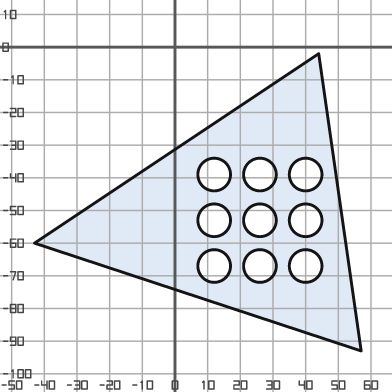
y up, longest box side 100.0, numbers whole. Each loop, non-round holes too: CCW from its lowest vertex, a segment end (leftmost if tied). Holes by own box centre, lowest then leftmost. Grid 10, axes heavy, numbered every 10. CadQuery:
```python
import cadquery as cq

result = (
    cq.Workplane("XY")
    .moveTo(57.0, -93.0)
    .lineTo(44.0, -2.0)
    .lineTo(-43.0, -60.0)
    .close()
    .moveTo(12.0, -67.0)
    .circle(5.0)
    .moveTo(26.0, -67.0)
    .circle(5.0)
    .moveTo(40.0, -67.0)
    .circle(5.0)
    .moveTo(12.0, -53.0)
    .circle(5.0)
    .moveTo(26.0, -53.0)
    .circle(5.0)
    .moveTo(40.0, -53.0)
    .circle(5.0)
    .moveTo(12.0, -39.0)
    .circle(5.0)
    .moveTo(26.0, -39.0)
    .circle(5.0)
    .moveTo(40.0, -39.0)
    .circle(5.0)
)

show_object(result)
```